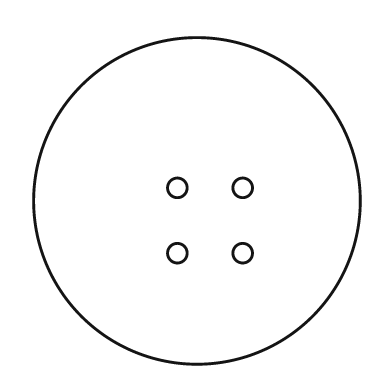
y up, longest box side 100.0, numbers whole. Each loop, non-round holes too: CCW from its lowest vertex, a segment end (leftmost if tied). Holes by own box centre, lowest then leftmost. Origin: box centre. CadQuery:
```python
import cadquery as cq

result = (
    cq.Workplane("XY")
    .moveTo(0.0, 0.0)
    .circle(50.0)
    .moveTo(-6.0, -16.0)
    .circle(3.0)
    .moveTo(14.0, -16.0)
    .circle(3.0)
    .moveTo(-6.0, 4.0)
    .circle(3.0)
    .moveTo(14.0, 4.0)
    .circle(3.0)
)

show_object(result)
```